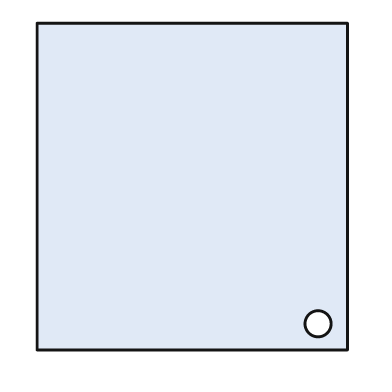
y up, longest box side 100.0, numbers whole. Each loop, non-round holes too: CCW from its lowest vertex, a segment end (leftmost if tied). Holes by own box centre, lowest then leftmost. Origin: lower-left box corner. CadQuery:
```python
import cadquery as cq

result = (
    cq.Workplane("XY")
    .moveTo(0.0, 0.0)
    .lineTo(95.0, 0.0)
    .lineTo(95.0, 100.0)
    .lineTo(0.0, 100.0)
    .close()
    .moveTo(86.0, 8.0)
    .circle(4.0)
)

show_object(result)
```